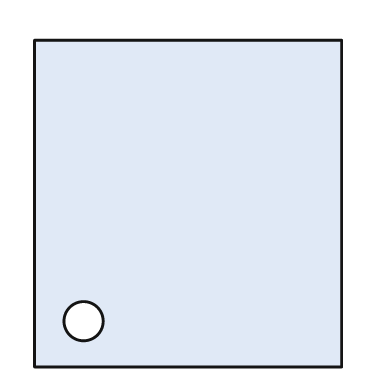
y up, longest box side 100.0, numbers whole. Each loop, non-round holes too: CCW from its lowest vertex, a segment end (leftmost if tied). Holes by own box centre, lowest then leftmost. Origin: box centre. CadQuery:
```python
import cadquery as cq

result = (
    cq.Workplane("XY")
    .moveTo(-47.0, -50.0)
    .lineTo(47.0, -50.0)
    .lineTo(47.0, 50.0)
    .lineTo(-47.0, 50.0)
    .close()
    .moveTo(-32.0, -36.0)
    .circle(6.0)
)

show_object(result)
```